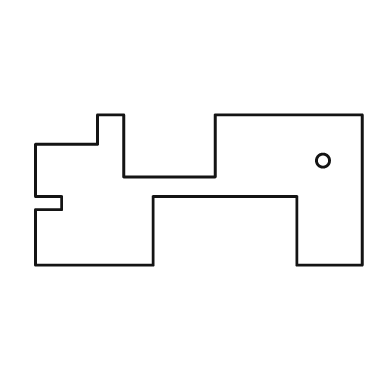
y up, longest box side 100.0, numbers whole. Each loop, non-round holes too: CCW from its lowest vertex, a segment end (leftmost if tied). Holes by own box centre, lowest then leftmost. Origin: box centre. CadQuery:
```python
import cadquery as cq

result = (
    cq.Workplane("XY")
    .moveTo(-50.0, -23.0)
    .lineTo(-14.0, -23.0)
    .lineTo(-14.0, -2.0)
    .lineTo(30.0, -2.0)
    .lineTo(30.0, -23.0)
    .lineTo(50.0, -23.0)
    .lineTo(50.0, 23.0)
    .lineTo(5.0, 23.0)
    .lineTo(5.0, 4.0)
    .lineTo(-23.0, 4.0)
    .lineTo(-23.0, 23.0)
    .lineTo(-31.0, 23.0)
    .lineTo(-31.0, 14.0)
    .lineTo(-50.0, 14.0)
    .lineTo(-50.0, -2.0)
    .lineTo(-42.0, -2.0)
    .lineTo(-42.0, -6.0)
    .lineTo(-50.0, -6.0)
    .close()
    .moveTo(38.0, 9.0)
    .circle(2.0)
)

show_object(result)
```